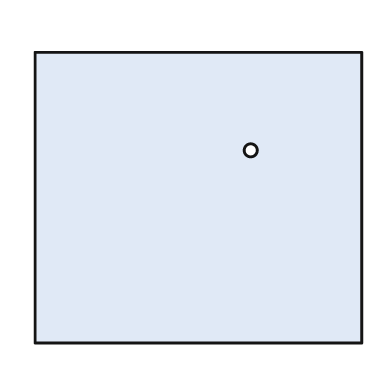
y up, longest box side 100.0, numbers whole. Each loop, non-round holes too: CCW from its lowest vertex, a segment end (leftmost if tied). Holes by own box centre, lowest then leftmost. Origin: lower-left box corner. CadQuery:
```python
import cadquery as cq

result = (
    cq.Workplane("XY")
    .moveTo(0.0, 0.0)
    .lineTo(100.0, 0.0)
    .lineTo(100.0, 89.0)
    .lineTo(0.0, 89.0)
    .close()
    .moveTo(66.0, 59.0)
    .circle(2.0)
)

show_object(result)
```